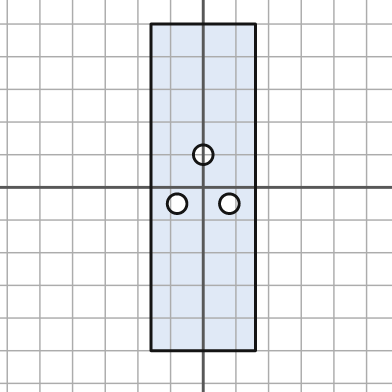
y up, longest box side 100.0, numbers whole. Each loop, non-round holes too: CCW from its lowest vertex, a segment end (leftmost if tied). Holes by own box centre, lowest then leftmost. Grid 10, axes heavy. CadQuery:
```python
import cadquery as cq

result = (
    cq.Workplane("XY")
    .moveTo(-16.0, -50.0)
    .lineTo(16.0, -50.0)
    .lineTo(16.0, 50.0)
    .lineTo(-16.0, 50.0)
    .close()
    .moveTo(-8.0, -5.0)
    .circle(3.0)
    .moveTo(8.0, -5.0)
    .circle(3.0)
    .moveTo(0.0, 10.0)
    .circle(3.0)
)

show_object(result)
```